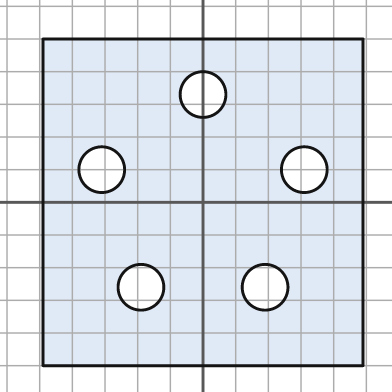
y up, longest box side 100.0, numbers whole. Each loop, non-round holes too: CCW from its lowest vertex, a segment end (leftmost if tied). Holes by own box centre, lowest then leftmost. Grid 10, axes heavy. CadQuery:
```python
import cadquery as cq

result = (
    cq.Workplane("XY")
    .moveTo(-49.0, -50.0)
    .lineTo(49.0, -50.0)
    .lineTo(49.0, 50.0)
    .lineTo(-49.0, 50.0)
    .close()
    .moveTo(-19.0, -26.0)
    .circle(7.0)
    .moveTo(19.0, -26.0)
    .circle(7.0)
    .moveTo(-31.0, 10.0)
    .circle(7.0)
    .moveTo(31.0, 10.0)
    .circle(7.0)
    .moveTo(0.0, 33.0)
    .circle(7.0)
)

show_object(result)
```